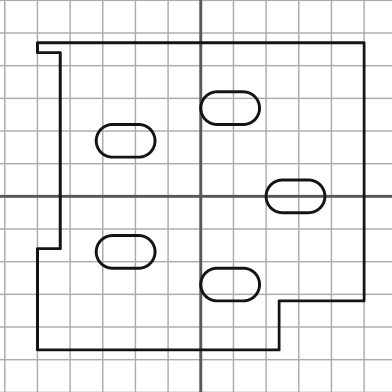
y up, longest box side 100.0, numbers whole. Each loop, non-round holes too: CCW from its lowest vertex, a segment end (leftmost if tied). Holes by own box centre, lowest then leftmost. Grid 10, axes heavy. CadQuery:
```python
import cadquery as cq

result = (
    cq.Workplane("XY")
    .moveTo(-50.0, -47.0)
    .lineTo(24.0, -47.0)
    .lineTo(24.0, -32.0)
    .lineTo(50.0, -32.0)
    .lineTo(50.0, 47.0)
    .lineTo(-50.0, 47.0)
    .lineTo(-50.0, 44.0)
    .lineTo(-43.0, 44.0)
    .lineTo(-43.0, -16.0)
    .lineTo(-50.0, -16.0)
    .close()
    .moveTo(5.0, -32.0)
    .lineTo(13.0, -32.0)
    .threePointArc((18.0, -27.0), (13.0, -22.0))
    .lineTo(5.0, -22.0)
    .threePointArc((0.0, -27.0), (5.0, -32.0))
    .close()
    .moveTo(-27.0, -22.0)
    .lineTo(-19.0, -22.0)
    .threePointArc((-14.0, -17.0), (-19.0, -12.0))
    .lineTo(-27.0, -12.0)
    .threePointArc((-32.0, -17.0), (-27.0, -22.0))
    .close()
    .moveTo(25.0, -5.0)
    .lineTo(33.0, -5.0)
    .threePointArc((38.0, 0.0), (33.0, 5.0))
    .lineTo(25.0, 5.0)
    .threePointArc((20.0, 0.0), (25.0, -5.0))
    .close()
    .moveTo(-27.0, 12.0)
    .lineTo(-19.0, 12.0)
    .threePointArc((-14.0, 17.0), (-19.0, 22.0))
    .lineTo(-27.0, 22.0)
    .threePointArc((-32.0, 17.0), (-27.0, 12.0))
    .close()
    .moveTo(5.0, 22.0)
    .lineTo(13.0, 22.0)
    .threePointArc((18.0, 27.0), (13.0, 32.0))
    .lineTo(5.0, 32.0)
    .threePointArc((0.0, 27.0), (5.0, 22.0))
    .close()
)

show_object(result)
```